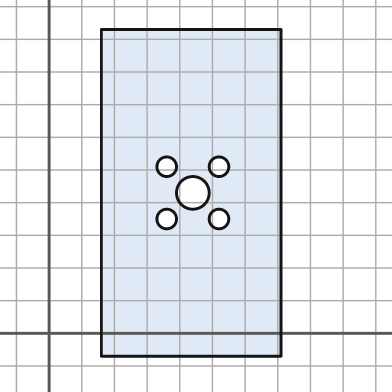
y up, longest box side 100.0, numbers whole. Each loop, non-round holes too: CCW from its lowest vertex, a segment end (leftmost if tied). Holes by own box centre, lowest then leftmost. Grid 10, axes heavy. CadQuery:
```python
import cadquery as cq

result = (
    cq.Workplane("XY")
    .moveTo(16.0, -7.0)
    .lineTo(71.0, -7.0)
    .lineTo(71.0, 93.0)
    .lineTo(16.0, 93.0)
    .close()
    .moveTo(36.0, 35.0)
    .circle(3.0)
    .moveTo(52.0, 35.0)
    .circle(3.0)
    .moveTo(44.0, 43.0)
    .circle(5.0)
    .moveTo(36.0, 51.0)
    .circle(3.0)
    .moveTo(52.0, 51.0)
    .circle(3.0)
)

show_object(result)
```